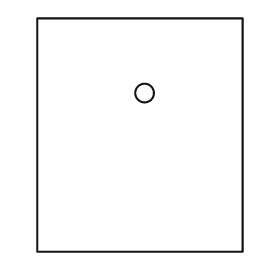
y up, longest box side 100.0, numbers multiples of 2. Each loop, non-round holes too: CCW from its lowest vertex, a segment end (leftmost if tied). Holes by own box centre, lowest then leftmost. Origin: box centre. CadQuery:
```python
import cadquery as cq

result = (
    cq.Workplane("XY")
    .moveTo(-44.0, -50.0)
    .lineTo(44.0, -50.0)
    .lineTo(44.0, 50.0)
    .lineTo(-44.0, 50.0)
    .close()
    .moveTo(2.0, 18.0)
    .circle(4.0)
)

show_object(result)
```